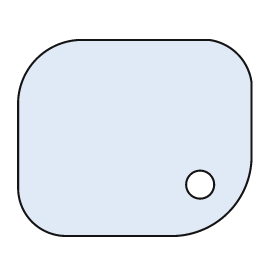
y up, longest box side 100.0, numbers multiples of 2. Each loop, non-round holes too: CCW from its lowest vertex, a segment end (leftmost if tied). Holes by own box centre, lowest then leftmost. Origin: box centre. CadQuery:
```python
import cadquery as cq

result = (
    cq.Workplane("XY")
    .moveTo(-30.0, -42.0)
    .lineTo(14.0, -42.0)
    .threePointArc((40.0, -32.0), (50.0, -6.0))
    .lineTo(50.0, 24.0)
    .threePointArc((44.0, 36.0), (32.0, 42.0))
    .lineTo(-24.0, 42.0)
    .threePointArc((-42.0, 34.0), (-50.0, 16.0))
    .lineTo(-50.0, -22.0)
    .threePointArc((-44.0, -36.0), (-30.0, -42.0))
    .close()
    .moveTo(28.0, -20.0)
    .circle(6.0)
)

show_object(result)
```